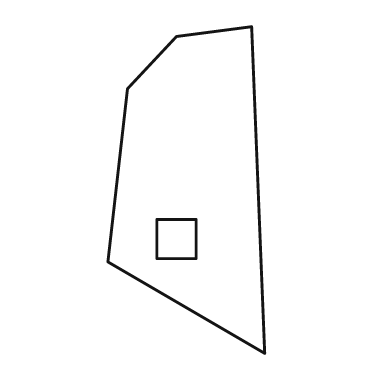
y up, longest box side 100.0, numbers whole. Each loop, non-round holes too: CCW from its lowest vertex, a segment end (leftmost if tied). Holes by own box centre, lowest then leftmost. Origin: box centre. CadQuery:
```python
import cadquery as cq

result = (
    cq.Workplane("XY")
    .moveTo(24.0, -50.0)
    .lineTo(20.0, 50.0)
    .lineTo(-3.0, 47.0)
    .lineTo(-18.0, 31.0)
    .lineTo(-24.0, -22.0)
    .close()
    .moveTo(-9.0, -21.0)
    .lineTo(3.0, -21.0)
    .lineTo(3.0, -9.0)
    .lineTo(-9.0, -9.0)
    .close()
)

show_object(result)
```